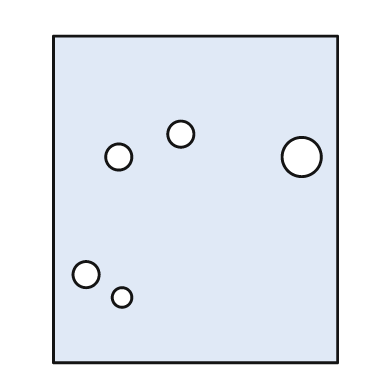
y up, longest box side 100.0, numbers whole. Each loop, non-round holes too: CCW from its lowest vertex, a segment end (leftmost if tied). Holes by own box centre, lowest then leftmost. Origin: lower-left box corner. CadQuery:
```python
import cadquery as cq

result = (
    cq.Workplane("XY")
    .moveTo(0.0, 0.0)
    .lineTo(87.0, 0.0)
    .lineTo(87.0, 100.0)
    .lineTo(0.0, 100.0)
    .close()
    .moveTo(21.0, 20.0)
    .circle(3.0)
    .moveTo(10.0, 27.0)
    .circle(4.0)
    .moveTo(20.0, 63.0)
    .circle(4.0)
    .moveTo(76.0, 63.0)
    .circle(6.0)
    .moveTo(39.0, 70.0)
    .circle(4.0)
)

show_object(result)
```